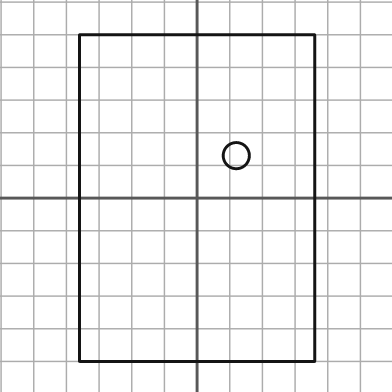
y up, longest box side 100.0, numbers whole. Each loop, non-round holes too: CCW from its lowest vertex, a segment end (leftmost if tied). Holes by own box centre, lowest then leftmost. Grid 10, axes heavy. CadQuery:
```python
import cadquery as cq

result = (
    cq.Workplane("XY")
    .moveTo(-36.0, -50.0)
    .lineTo(36.0, -50.0)
    .lineTo(36.0, 50.0)
    .lineTo(-36.0, 50.0)
    .close()
    .moveTo(12.0, 13.0)
    .circle(4.0)
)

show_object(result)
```